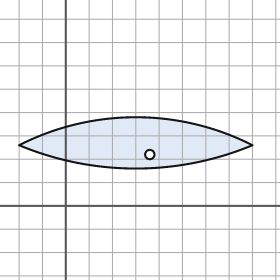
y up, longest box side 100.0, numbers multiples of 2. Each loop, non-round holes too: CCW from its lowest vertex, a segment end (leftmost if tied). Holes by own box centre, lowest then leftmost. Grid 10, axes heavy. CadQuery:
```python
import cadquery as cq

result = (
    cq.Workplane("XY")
    .moveTo(-20.0, 26.0)
    .threePointArc((30.0, 16.0), (80.0, 26.0))
    .threePointArc((30.0, 38.0), (-20.0, 26.0))
    .close()
    .moveTo(36.0, 22.0)
    .circle(2.0)
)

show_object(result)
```